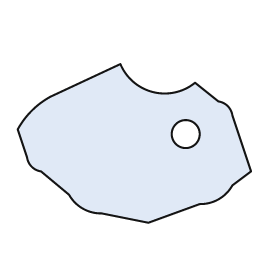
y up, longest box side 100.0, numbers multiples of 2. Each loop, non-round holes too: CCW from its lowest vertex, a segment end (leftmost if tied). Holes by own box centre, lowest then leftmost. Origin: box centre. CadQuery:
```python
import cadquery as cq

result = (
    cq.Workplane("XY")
    .moveTo(6.0, -34.0)
    .lineTo(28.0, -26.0)
    .threePointArc((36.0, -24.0), (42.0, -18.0))
    .lineTo(50.0, -12.0)
    .lineTo(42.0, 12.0)
    .threePointArc((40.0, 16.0), (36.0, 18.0))
    .lineTo(26.0, 26.0)
    .threePointArc((8.0, 22.0), (-6.0, 34.0))
    .lineTo(-36.0, 20.0)
    .threePointArc((-44.0, 14.0), (-50.0, 6.0))
    .lineTo(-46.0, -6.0)
    .threePointArc((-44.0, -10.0), (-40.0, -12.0))
    .lineTo(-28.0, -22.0)
    .threePointArc((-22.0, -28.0), (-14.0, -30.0))
    .close()
    .moveTo(22.0, 4.0)
    .circle(6.0)
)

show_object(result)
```